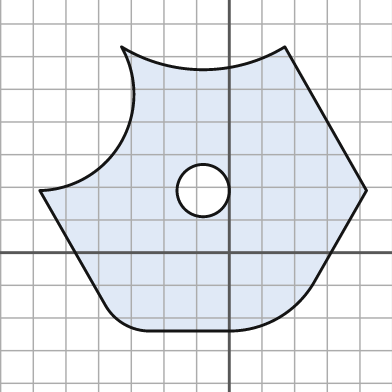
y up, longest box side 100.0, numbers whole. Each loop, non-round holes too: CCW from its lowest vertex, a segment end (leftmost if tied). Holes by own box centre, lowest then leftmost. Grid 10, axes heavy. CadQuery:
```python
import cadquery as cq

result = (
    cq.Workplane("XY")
    .moveTo(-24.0, -24.0)
    .lineTo(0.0, -24.0)
    .threePointArc((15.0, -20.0), (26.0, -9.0))
    .lineTo(42.0, 19.0)
    .lineTo(17.0, 63.0)
    .threePointArc((-8.0, 56.0), (-33.0, 63.0))
    .threePointArc((-33.0, 34.0), (-58.0, 19.0))
    .lineTo(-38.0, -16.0)
    .threePointArc((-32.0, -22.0), (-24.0, -24.0))
    .close()
    .moveTo(-8.0, 19.0)
    .circle(8.0)
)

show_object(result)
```